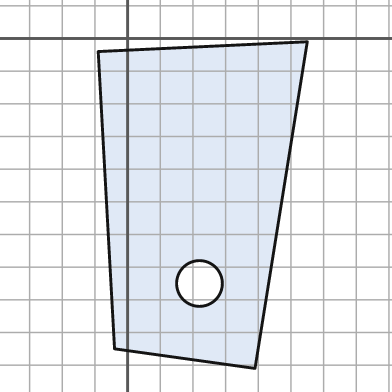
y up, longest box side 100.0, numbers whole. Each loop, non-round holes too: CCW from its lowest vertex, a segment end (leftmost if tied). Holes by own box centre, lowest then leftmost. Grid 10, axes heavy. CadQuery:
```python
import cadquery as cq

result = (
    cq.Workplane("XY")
    .moveTo(39.0, -101.0)
    .lineTo(55.0, -1.0)
    .lineTo(-9.0, -4.0)
    .lineTo(-4.0, -95.0)
    .close()
    .moveTo(22.0, -75.0)
    .circle(7.0)
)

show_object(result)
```